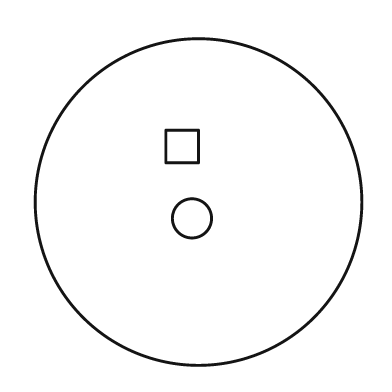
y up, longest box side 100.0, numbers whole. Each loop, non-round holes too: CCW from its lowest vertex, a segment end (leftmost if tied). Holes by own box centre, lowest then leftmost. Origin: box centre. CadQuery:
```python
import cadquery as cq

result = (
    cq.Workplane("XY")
    .moveTo(0.0, 0.0)
    .circle(50.0)
    .moveTo(-2.0, -5.0)
    .circle(6.0)
    .moveTo(-10.0, 12.0)
    .lineTo(0.0, 12.0)
    .lineTo(0.0, 22.0)
    .lineTo(-10.0, 22.0)
    .close()
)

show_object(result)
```